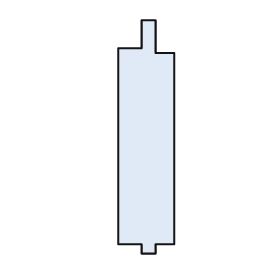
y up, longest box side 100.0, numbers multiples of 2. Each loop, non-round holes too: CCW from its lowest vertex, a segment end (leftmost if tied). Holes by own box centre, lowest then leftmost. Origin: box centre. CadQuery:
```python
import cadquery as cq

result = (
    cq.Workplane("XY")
    .moveTo(-2.0, -50.0)
    .lineTo(4.0, -50.0)
    .lineTo(4.0, -46.0)
    .lineTo(12.0, -46.0)
    .lineTo(12.0, 36.0)
    .lineTo(4.0, 36.0)
    .lineTo(4.0, 50.0)
    .lineTo(-2.0, 50.0)
    .lineTo(-2.0, 38.0)
    .lineTo(-12.0, 38.0)
    .lineTo(-12.0, -46.0)
    .lineTo(-2.0, -46.0)
    .close()
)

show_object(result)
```